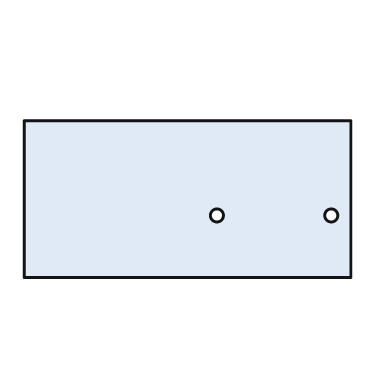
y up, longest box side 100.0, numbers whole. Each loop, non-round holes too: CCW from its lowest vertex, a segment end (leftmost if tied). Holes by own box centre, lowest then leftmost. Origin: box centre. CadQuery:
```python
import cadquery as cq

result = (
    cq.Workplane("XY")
    .moveTo(-50.0, -24.0)
    .lineTo(50.0, -24.0)
    .lineTo(50.0, 24.0)
    .lineTo(-50.0, 24.0)
    .close()
    .moveTo(9.0, -5.0)
    .circle(2.0)
    .moveTo(44.0, -5.0)
    .circle(2.0)
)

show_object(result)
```